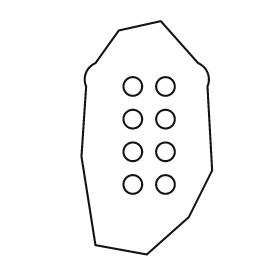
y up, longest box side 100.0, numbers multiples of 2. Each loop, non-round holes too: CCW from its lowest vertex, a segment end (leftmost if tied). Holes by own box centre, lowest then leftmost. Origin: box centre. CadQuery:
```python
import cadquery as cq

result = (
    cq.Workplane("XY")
    .moveTo(0.0, -50.0)
    .lineTo(18.0, -34.0)
    .lineTo(28.0, -14.0)
    .lineTo(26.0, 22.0)
    .threePointArc((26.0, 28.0), (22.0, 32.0))
    .lineTo(6.0, 50.0)
    .lineTo(-12.0, 46.0)
    .lineTo(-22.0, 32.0)
    .threePointArc((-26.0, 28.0), (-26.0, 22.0))
    .lineTo(-28.0, -8.0)
    .lineTo(-22.0, -46.0)
    .close()
    .moveTo(-6.0, -20.0)
    .circle(4.0)
    .moveTo(8.0, -20.0)
    .circle(4.0)
    .moveTo(-6.0, -6.0)
    .circle(4.0)
    .moveTo(8.0, -6.0)
    .circle(4.0)
    .moveTo(-6.0, 8.0)
    .circle(4.0)
    .moveTo(8.0, 8.0)
    .circle(4.0)
    .moveTo(-6.0, 22.0)
    .circle(4.0)
    .moveTo(8.0, 22.0)
    .circle(4.0)
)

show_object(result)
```